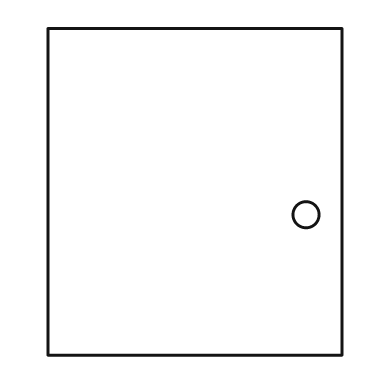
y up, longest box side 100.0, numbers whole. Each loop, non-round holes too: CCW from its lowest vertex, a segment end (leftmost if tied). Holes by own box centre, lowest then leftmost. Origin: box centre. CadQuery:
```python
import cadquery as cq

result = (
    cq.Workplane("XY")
    .moveTo(-45.0, -50.0)
    .lineTo(45.0, -50.0)
    .lineTo(45.0, 50.0)
    .lineTo(-45.0, 50.0)
    .close()
    .moveTo(34.0, -7.0)
    .circle(4.0)
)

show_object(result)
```